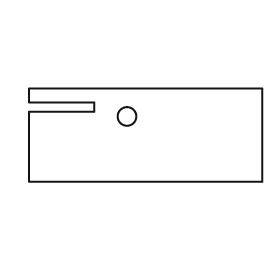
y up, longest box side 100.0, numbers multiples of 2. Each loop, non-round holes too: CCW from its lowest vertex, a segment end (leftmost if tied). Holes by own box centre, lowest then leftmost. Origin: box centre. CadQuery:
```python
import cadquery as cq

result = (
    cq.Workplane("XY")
    .moveTo(-50.0, -20.0)
    .lineTo(50.0, -20.0)
    .lineTo(50.0, 20.0)
    .lineTo(-50.0, 20.0)
    .lineTo(-50.0, 14.0)
    .lineTo(-22.0, 14.0)
    .lineTo(-22.0, 10.0)
    .lineTo(-50.0, 10.0)
    .close()
    .moveTo(-8.0, 8.0)
    .circle(4.0)
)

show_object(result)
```